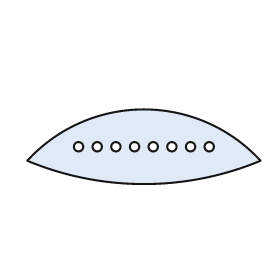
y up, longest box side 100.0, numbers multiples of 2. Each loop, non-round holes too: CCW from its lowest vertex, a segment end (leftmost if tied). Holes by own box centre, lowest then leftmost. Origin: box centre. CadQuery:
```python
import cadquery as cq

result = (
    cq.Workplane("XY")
    .moveTo(-50.0, -6.0)
    .threePointArc((0.0, -16.0), (50.0, -6.0))
    .threePointArc((0.0, 16.0), (-50.0, -6.0))
    .close()
    .moveTo(-28.0, 0.0)
    .circle(2.0)
    .moveTo(-20.0, 0.0)
    .circle(2.0)
    .moveTo(-12.0, 0.0)
    .circle(2.0)
    .moveTo(-4.0, 0.0)
    .circle(2.0)
    .moveTo(4.0, 0.0)
    .circle(2.0)
    .moveTo(12.0, 0.0)
    .circle(2.0)
    .moveTo(20.0, 0.0)
    .circle(2.0)
    .moveTo(28.0, 0.0)
    .circle(2.0)
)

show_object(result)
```